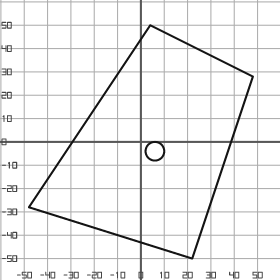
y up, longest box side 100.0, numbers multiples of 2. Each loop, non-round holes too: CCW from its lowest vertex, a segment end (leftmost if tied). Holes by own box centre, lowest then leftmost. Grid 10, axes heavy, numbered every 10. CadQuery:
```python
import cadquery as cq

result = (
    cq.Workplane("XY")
    .moveTo(22.0, -50.0)
    .lineTo(48.0, 28.0)
    .lineTo(4.0, 50.0)
    .lineTo(-48.0, -28.0)
    .close()
    .moveTo(6.0, -4.0)
    .circle(4.0)
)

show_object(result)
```